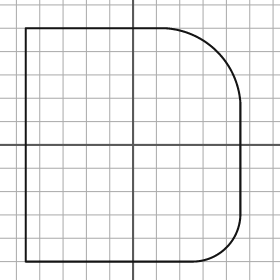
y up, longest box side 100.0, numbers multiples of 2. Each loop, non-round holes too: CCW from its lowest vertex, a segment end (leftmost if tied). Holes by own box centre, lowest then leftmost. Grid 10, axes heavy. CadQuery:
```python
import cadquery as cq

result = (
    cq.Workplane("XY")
    .moveTo(-46.0, -50.0)
    .lineTo(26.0, -50.0)
    .threePointArc((40.0, -44.0), (46.0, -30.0))
    .lineTo(46.0, 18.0)
    .threePointArc((36.0, 40.0), (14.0, 50.0))
    .lineTo(-46.0, 50.0)
    .close()
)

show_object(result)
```